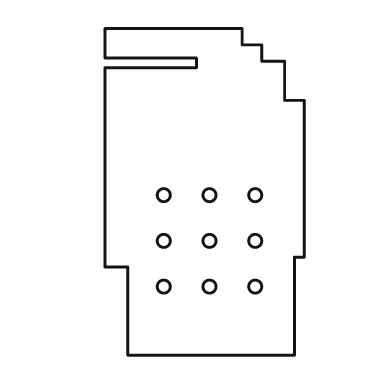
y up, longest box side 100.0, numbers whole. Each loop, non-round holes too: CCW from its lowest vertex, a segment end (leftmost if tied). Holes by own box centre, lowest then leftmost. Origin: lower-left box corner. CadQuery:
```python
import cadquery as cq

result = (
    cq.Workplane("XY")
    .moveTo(7.0, 0.0)
    .lineTo(58.0, 0.0)
    .lineTo(58.0, 30.0)
    .lineTo(61.0, 30.0)
    .lineTo(61.0, 78.0)
    .lineTo(55.0, 78.0)
    .lineTo(55.0, 90.0)
    .lineTo(48.0, 90.0)
    .lineTo(48.0, 95.0)
    .lineTo(42.0, 95.0)
    .lineTo(42.0, 100.0)
    .lineTo(0.0, 100.0)
    .lineTo(0.0, 91.0)
    .lineTo(28.0, 91.0)
    .lineTo(28.0, 88.0)
    .lineTo(0.0, 88.0)
    .lineTo(0.0, 27.0)
    .lineTo(7.0, 27.0)
    .close()
    .moveTo(18.0, 21.0)
    .circle(2.0)
    .moveTo(32.0, 21.0)
    .circle(2.0)
    .moveTo(46.0, 21.0)
    .circle(2.0)
    .moveTo(18.0, 35.0)
    .circle(2.0)
    .moveTo(32.0, 35.0)
    .circle(2.0)
    .moveTo(46.0, 35.0)
    .circle(2.0)
    .moveTo(18.0, 49.0)
    .circle(2.0)
    .moveTo(32.0, 49.0)
    .circle(2.0)
    .moveTo(46.0, 49.0)
    .circle(2.0)
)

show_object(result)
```